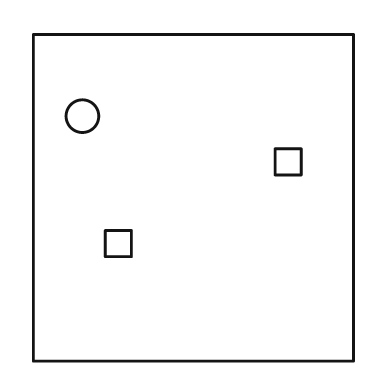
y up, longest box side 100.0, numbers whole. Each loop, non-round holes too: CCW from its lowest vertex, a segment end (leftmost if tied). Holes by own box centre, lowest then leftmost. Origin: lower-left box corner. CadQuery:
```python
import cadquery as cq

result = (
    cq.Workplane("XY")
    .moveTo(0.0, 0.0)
    .lineTo(98.0, 0.0)
    .lineTo(98.0, 100.0)
    .lineTo(0.0, 100.0)
    .close()
    .moveTo(22.0, 32.0)
    .lineTo(30.0, 32.0)
    .lineTo(30.0, 40.0)
    .lineTo(22.0, 40.0)
    .close()
    .moveTo(74.0, 57.0)
    .lineTo(82.0, 57.0)
    .lineTo(82.0, 65.0)
    .lineTo(74.0, 65.0)
    .close()
    .moveTo(15.0, 75.0)
    .circle(5.0)
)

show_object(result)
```